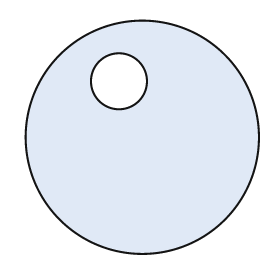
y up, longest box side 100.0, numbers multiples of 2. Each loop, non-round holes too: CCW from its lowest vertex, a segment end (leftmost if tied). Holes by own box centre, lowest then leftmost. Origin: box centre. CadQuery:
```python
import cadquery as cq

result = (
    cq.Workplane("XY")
    .moveTo(0.0, 0.0)
    .circle(50.0)
    .moveTo(-10.0, 24.0)
    .circle(12.0)
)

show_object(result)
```